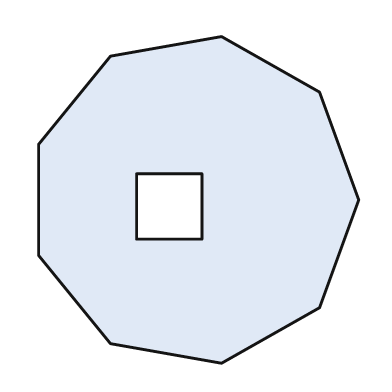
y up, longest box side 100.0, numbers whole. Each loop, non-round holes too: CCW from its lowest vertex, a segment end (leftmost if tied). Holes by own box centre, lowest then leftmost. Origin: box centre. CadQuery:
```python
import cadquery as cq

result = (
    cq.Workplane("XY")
    .moveTo(7.0, -50.0)
    .lineTo(37.0, -33.0)
    .lineTo(49.0, 0.0)
    .lineTo(37.0, 33.0)
    .lineTo(7.0, 50.0)
    .lineTo(-27.0, 44.0)
    .lineTo(-49.0, 17.0)
    .lineTo(-49.0, -17.0)
    .lineTo(-27.0, -44.0)
    .close()
    .moveTo(-19.0, -12.0)
    .lineTo(1.0, -12.0)
    .lineTo(1.0, 8.0)
    .lineTo(-19.0, 8.0)
    .close()
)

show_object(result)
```